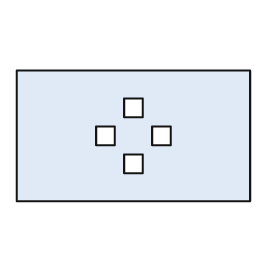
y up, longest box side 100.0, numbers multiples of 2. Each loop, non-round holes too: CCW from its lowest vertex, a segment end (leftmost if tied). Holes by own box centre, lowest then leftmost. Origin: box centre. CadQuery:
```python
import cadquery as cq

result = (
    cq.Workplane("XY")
    .moveTo(-50.0, -28.0)
    .lineTo(50.0, -28.0)
    .lineTo(50.0, 28.0)
    .lineTo(-50.0, 28.0)
    .close()
    .moveTo(-4.0, -16.0)
    .lineTo(4.0, -16.0)
    .lineTo(4.0, -8.0)
    .lineTo(-4.0, -8.0)
    .close()
    .moveTo(-16.0, -4.0)
    .lineTo(-8.0, -4.0)
    .lineTo(-8.0, 4.0)
    .lineTo(-16.0, 4.0)
    .close()
    .moveTo(8.0, -4.0)
    .lineTo(16.0, -4.0)
    .lineTo(16.0, 4.0)
    .lineTo(8.0, 4.0)
    .close()
    .moveTo(-4.0, 8.0)
    .lineTo(4.0, 8.0)
    .lineTo(4.0, 16.0)
    .lineTo(-4.0, 16.0)
    .close()
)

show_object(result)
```